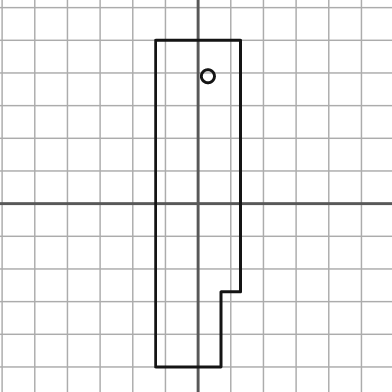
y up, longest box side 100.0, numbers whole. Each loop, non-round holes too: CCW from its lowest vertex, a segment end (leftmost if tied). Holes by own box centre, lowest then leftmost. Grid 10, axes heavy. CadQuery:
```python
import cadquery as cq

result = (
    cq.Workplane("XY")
    .moveTo(-13.0, -50.0)
    .lineTo(7.0, -50.0)
    .lineTo(7.0, -27.0)
    .lineTo(13.0, -27.0)
    .lineTo(13.0, 50.0)
    .lineTo(-13.0, 50.0)
    .close()
    .moveTo(3.0, 39.0)
    .circle(2.0)
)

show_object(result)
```